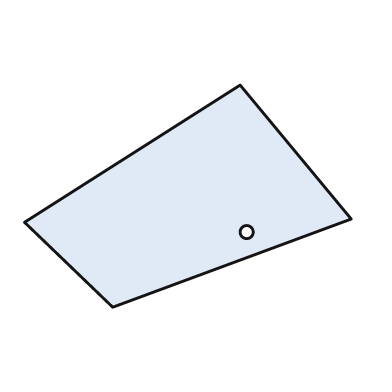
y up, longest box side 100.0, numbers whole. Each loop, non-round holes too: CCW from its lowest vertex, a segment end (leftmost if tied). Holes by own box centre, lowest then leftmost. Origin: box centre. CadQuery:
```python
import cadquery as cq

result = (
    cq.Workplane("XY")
    .moveTo(-23.0, -34.0)
    .lineTo(50.0, -7.0)
    .lineTo(16.0, 34.0)
    .lineTo(-50.0, -8.0)
    .close()
    .moveTo(18.0, -11.0)
    .circle(2.0)
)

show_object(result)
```